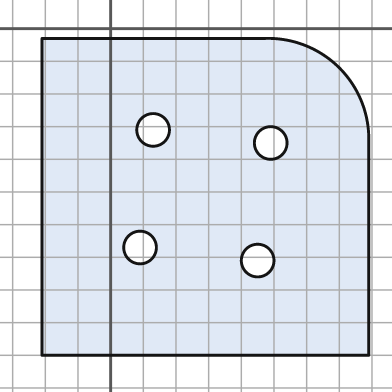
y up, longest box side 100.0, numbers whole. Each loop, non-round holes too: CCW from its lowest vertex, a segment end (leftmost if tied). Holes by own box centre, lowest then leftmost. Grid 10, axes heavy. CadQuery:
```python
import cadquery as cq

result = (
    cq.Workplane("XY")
    .moveTo(-21.0, -100.0)
    .lineTo(79.0, -100.0)
    .lineTo(79.0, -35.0)
    .threePointArc((70.0, -12.0), (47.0, -3.0))
    .lineTo(-21.0, -3.0)
    .close()
    .moveTo(45.0, -71.0)
    .circle(5.0)
    .moveTo(9.0, -67.0)
    .circle(5.0)
    .moveTo(49.0, -35.0)
    .circle(5.0)
    .moveTo(13.0, -31.0)
    .circle(5.0)
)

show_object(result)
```